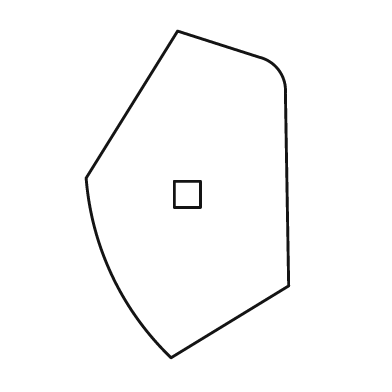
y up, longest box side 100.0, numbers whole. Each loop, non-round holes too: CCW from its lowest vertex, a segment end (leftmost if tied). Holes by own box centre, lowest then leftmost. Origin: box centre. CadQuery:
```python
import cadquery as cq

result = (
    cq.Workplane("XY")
    .moveTo(-5.0, -50.0)
    .lineTo(31.0, -28.0)
    .lineTo(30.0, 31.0)
    .threePointArc((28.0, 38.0), (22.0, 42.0))
    .lineTo(-3.0, 50.0)
    .lineTo(-31.0, 5.0)
    .threePointArc((-23.0, -25.0), (-5.0, -50.0))
    .close()
    .moveTo(-4.0, -4.0)
    .lineTo(4.0, -4.0)
    .lineTo(4.0, 4.0)
    .lineTo(-4.0, 4.0)
    .close()
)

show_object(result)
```